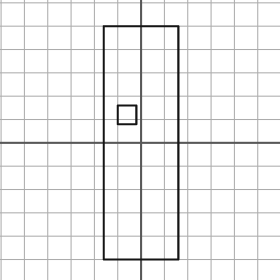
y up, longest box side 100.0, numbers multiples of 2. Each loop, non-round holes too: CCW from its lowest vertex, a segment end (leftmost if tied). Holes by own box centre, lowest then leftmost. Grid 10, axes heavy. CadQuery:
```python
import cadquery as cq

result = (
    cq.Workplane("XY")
    .moveTo(-16.0, -50.0)
    .lineTo(16.0, -50.0)
    .lineTo(16.0, 50.0)
    .lineTo(-16.0, 50.0)
    .close()
    .moveTo(-10.0, 8.0)
    .lineTo(-2.0, 8.0)
    .lineTo(-2.0, 16.0)
    .lineTo(-10.0, 16.0)
    .close()
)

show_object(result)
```